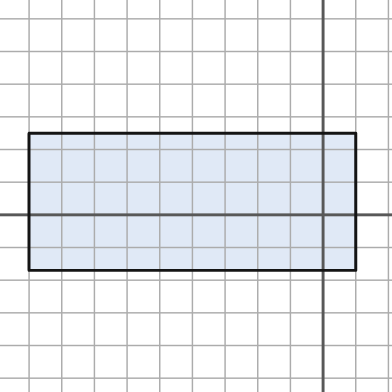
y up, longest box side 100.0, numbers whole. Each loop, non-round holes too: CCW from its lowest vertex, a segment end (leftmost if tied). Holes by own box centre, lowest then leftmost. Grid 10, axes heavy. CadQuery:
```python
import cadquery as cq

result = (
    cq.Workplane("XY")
    .moveTo(-90.0, -17.0)
    .lineTo(10.0, -17.0)
    .lineTo(10.0, 25.0)
    .lineTo(-90.0, 25.0)
    .close()
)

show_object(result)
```